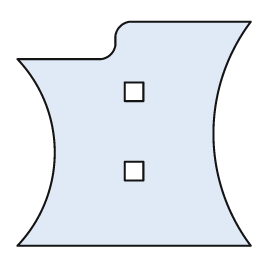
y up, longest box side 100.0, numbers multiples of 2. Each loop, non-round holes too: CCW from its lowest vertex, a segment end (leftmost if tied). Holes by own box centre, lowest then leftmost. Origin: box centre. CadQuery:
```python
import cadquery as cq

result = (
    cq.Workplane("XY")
    .moveTo(-50.0, -48.0)
    .lineTo(50.0, -48.0)
    .threePointArc((34.0, 0.0), (50.0, 48.0))
    .lineTo(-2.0, 48.0)
    .threePointArc((-6.0, 46.0), (-8.0, 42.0))
    .lineTo(-8.0, 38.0)
    .threePointArc((-10.0, 34.0), (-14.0, 32.0))
    .lineTo(-50.0, 32.0)
    .threePointArc((-34.0, -8.0), (-50.0, -48.0))
    .close()
    .moveTo(-4.0, -20.0)
    .lineTo(4.0, -20.0)
    .lineTo(4.0, -12.0)
    .lineTo(-4.0, -12.0)
    .close()
    .moveTo(-4.0, 14.0)
    .lineTo(4.0, 14.0)
    .lineTo(4.0, 22.0)
    .lineTo(-4.0, 22.0)
    .close()
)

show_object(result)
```